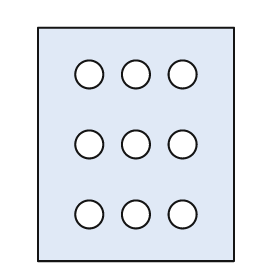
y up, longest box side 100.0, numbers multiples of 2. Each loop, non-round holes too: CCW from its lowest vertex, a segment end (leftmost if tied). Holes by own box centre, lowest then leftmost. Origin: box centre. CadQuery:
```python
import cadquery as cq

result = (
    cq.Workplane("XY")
    .moveTo(-42.0, -50.0)
    .lineTo(42.0, -50.0)
    .lineTo(42.0, 50.0)
    .lineTo(-42.0, 50.0)
    .close()
    .moveTo(-20.0, -30.0)
    .circle(6.0)
    .moveTo(0.0, -30.0)
    .circle(6.0)
    .moveTo(20.0, -30.0)
    .circle(6.0)
    .moveTo(-20.0, 0.0)
    .circle(6.0)
    .moveTo(0.0, 0.0)
    .circle(6.0)
    .moveTo(20.0, 0.0)
    .circle(6.0)
    .moveTo(-20.0, 30.0)
    .circle(6.0)
    .moveTo(0.0, 30.0)
    .circle(6.0)
    .moveTo(20.0, 30.0)
    .circle(6.0)
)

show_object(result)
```